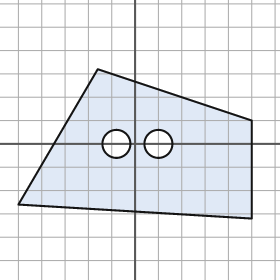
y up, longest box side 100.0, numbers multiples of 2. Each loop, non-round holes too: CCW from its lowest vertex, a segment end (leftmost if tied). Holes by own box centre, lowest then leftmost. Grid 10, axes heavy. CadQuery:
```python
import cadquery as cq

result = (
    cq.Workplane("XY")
    .moveTo(50.0, -32.0)
    .lineTo(50.0, 10.0)
    .lineTo(-16.0, 32.0)
    .lineTo(-50.0, -26.0)
    .close()
    .moveTo(-8.0, 0.0)
    .circle(6.0)
    .moveTo(10.0, 0.0)
    .circle(6.0)
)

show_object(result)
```